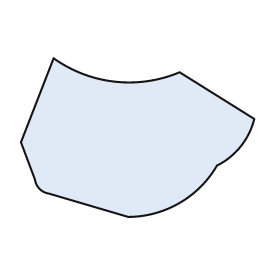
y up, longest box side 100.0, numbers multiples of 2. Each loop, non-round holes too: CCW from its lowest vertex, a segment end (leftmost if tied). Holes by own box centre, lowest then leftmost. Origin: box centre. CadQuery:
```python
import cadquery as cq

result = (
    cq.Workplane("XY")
    .moveTo(-4.0, -34.0)
    .threePointArc((18.0, -28.0), (34.0, -12.0))
    .threePointArc((44.0, -4.0), (50.0, 8.0))
    .lineTo(18.0, 28.0)
    .threePointArc((-10.0, 24.0), (-36.0, 34.0))
    .lineTo(-50.0, -2.0)
    .lineTo(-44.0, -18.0)
    .threePointArc((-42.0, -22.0), (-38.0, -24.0))
    .close()
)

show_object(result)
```